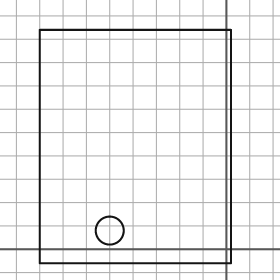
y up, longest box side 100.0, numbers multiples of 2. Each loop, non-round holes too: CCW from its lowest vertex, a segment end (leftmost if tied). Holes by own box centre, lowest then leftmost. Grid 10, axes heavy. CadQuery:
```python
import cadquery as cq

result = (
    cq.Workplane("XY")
    .moveTo(-80.0, -6.0)
    .lineTo(2.0, -6.0)
    .lineTo(2.0, 94.0)
    .lineTo(-80.0, 94.0)
    .close()
    .moveTo(-50.0, 8.0)
    .circle(6.0)
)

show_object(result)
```